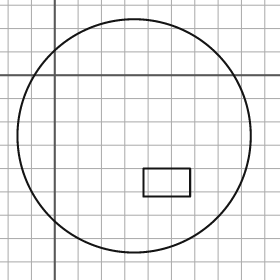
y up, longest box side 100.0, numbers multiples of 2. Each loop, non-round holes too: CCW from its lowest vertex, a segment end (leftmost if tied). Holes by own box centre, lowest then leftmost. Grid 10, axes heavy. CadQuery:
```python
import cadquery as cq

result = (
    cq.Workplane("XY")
    .moveTo(34.0, -26.0)
    .circle(50.0)
    .moveTo(38.0, -52.0)
    .lineTo(58.0, -52.0)
    .lineTo(58.0, -40.0)
    .lineTo(38.0, -40.0)
    .close()
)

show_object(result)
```